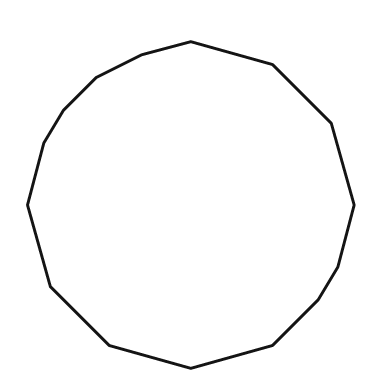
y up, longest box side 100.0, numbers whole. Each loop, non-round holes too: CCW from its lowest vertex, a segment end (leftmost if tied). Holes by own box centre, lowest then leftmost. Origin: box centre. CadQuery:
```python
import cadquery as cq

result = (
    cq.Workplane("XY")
    .moveTo(0.0, -50.0)
    .lineTo(25.0, -43.0)
    .lineTo(39.0, -29.0)
    .lineTo(45.0, -19.0)
    .lineTo(50.0, 0.0)
    .lineTo(43.0, 25.0)
    .lineTo(25.0, 43.0)
    .lineTo(0.0, 50.0)
    .lineTo(-15.0, 46.0)
    .lineTo(-29.0, 39.0)
    .lineTo(-39.0, 29.0)
    .lineTo(-45.0, 19.0)
    .lineTo(-50.0, 0.0)
    .lineTo(-43.0, -25.0)
    .lineTo(-25.0, -43.0)
    .close()
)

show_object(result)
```